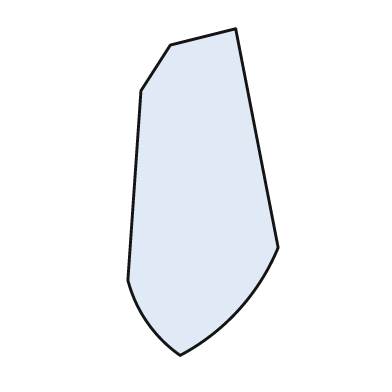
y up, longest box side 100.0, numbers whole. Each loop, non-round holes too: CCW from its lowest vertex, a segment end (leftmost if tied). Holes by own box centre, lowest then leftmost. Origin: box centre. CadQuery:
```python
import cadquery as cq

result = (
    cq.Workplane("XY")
    .moveTo(-7.0, -50.0)
    .threePointArc((11.0, -36.0), (23.0, -17.0))
    .lineTo(10.0, 50.0)
    .lineTo(-10.0, 45.0)
    .lineTo(-19.0, 31.0)
    .lineTo(-23.0, -27.0)
    .threePointArc((-17.0, -40.0), (-7.0, -50.0))
    .close()
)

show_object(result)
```